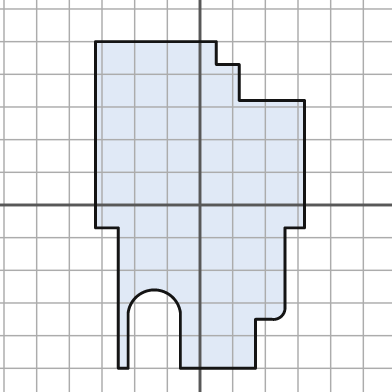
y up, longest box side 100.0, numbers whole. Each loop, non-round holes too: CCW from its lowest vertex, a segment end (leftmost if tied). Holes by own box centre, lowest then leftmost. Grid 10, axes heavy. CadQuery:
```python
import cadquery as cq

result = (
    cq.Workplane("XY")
    .moveTo(-25.0, -50.0)
    .lineTo(-22.0, -50.0)
    .lineTo(-22.0, -33.0)
    .threePointArc((-14.0, -26.0), (-6.0, -33.0))
    .lineTo(-6.0, -50.0)
    .lineTo(17.0, -50.0)
    .lineTo(17.0, -35.0)
    .lineTo(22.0, -35.0)
    .threePointArc((25.0, -34.0), (26.0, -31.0))
    .lineTo(26.0, -7.0)
    .lineTo(32.0, -7.0)
    .lineTo(32.0, 32.0)
    .lineTo(12.0, 32.0)
    .lineTo(12.0, 43.0)
    .lineTo(5.0, 43.0)
    .lineTo(5.0, 50.0)
    .lineTo(-32.0, 50.0)
    .lineTo(-32.0, -7.0)
    .lineTo(-25.0, -7.0)
    .close()
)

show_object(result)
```